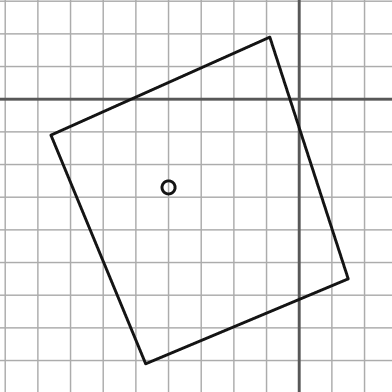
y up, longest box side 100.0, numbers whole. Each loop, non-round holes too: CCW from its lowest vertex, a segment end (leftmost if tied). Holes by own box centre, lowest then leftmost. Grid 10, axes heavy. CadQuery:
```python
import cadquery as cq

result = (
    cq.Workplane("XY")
    .moveTo(-47.0, -81.0)
    .lineTo(15.0, -55.0)
    .lineTo(-9.0, 19.0)
    .lineTo(-76.0, -11.0)
    .close()
    .moveTo(-40.0, -27.0)
    .circle(2.0)
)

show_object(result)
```